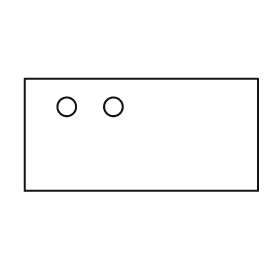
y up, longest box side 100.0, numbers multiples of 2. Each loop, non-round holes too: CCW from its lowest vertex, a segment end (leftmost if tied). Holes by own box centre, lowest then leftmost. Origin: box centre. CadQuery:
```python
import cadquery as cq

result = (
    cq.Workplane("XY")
    .moveTo(-50.0, -24.0)
    .lineTo(50.0, -24.0)
    .lineTo(50.0, 24.0)
    .lineTo(-50.0, 24.0)
    .close()
    .moveTo(-32.0, 12.0)
    .circle(4.0)
    .moveTo(-12.0, 12.0)
    .circle(4.0)
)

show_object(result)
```